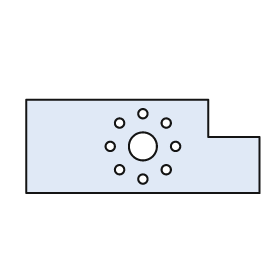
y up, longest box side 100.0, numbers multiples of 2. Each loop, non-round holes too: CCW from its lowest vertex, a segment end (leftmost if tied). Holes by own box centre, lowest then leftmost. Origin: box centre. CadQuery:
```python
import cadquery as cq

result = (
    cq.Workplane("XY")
    .moveTo(-50.0, -20.0)
    .lineTo(50.0, -20.0)
    .lineTo(50.0, 4.0)
    .lineTo(28.0, 4.0)
    .lineTo(28.0, 20.0)
    .lineTo(-50.0, 20.0)
    .close()
    .moveTo(0.0, -14.0)
    .circle(2.0)
    .moveTo(-10.0, -10.0)
    .circle(2.0)
    .moveTo(10.0, -10.0)
    .circle(2.0)
    .moveTo(-14.0, 0.0)
    .circle(2.0)
    .moveTo(0.0, 0.0)
    .circle(6.0)
    .moveTo(14.0, 0.0)
    .circle(2.0)
    .moveTo(-10.0, 10.0)
    .circle(2.0)
    .moveTo(10.0, 10.0)
    .circle(2.0)
    .moveTo(0.0, 14.0)
    .circle(2.0)
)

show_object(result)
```